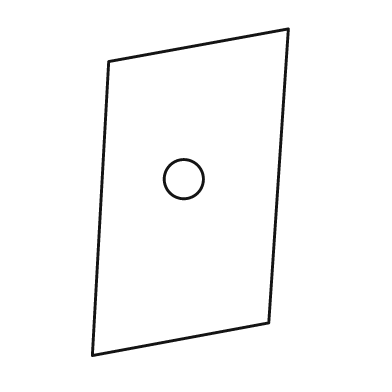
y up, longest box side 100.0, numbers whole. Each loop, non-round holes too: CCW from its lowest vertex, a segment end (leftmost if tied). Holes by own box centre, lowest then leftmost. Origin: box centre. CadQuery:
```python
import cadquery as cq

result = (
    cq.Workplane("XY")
    .moveTo(-30.0, -50.0)
    .lineTo(24.0, -40.0)
    .lineTo(30.0, 50.0)
    .lineTo(-25.0, 40.0)
    .close()
    .moveTo(-2.0, 4.0)
    .circle(6.0)
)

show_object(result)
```